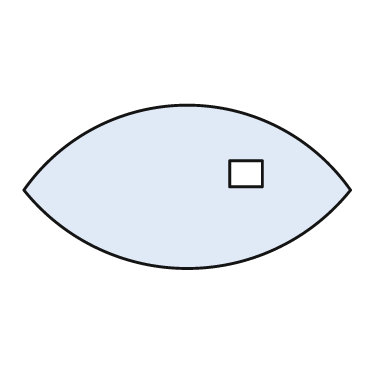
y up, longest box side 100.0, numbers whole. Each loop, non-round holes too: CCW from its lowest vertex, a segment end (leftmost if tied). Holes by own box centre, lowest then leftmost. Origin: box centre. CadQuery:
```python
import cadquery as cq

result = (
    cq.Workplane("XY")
    .moveTo(-50.0, -1.0)
    .threePointArc((0.0, -25.0), (50.0, -1.0))
    .threePointArc((0.0, 25.0), (-50.0, -1.0))
    .close()
    .moveTo(13.0, 0.0)
    .lineTo(23.0, 0.0)
    .lineTo(23.0, 8.0)
    .lineTo(13.0, 8.0)
    .close()
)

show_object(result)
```